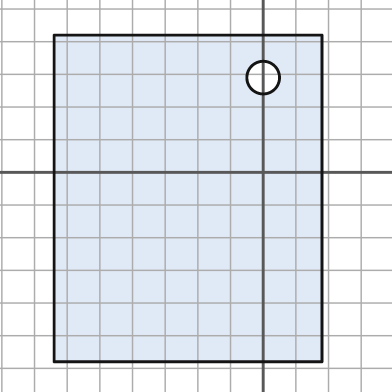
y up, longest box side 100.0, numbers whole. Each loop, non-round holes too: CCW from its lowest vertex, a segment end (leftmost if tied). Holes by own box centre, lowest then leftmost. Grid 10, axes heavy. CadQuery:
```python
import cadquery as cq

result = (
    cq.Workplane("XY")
    .moveTo(-64.0, -58.0)
    .lineTo(18.0, -58.0)
    .lineTo(18.0, 42.0)
    .lineTo(-64.0, 42.0)
    .close()
    .moveTo(0.0, 29.0)
    .circle(5.0)
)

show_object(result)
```